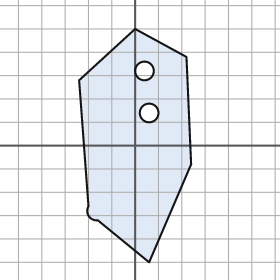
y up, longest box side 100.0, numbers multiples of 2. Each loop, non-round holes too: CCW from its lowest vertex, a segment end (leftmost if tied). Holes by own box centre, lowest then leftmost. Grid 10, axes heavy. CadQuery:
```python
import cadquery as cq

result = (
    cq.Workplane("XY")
    .moveTo(6.0, -50.0)
    .lineTo(24.0, -8.0)
    .lineTo(22.0, 38.0)
    .lineTo(0.0, 50.0)
    .lineTo(-24.0, 28.0)
    .lineTo(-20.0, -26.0)
    .threePointArc((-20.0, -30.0), (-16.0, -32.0))
    .close()
    .moveTo(6.0, 14.0)
    .circle(4.0)
    .moveTo(4.0, 32.0)
    .circle(4.0)
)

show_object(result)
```